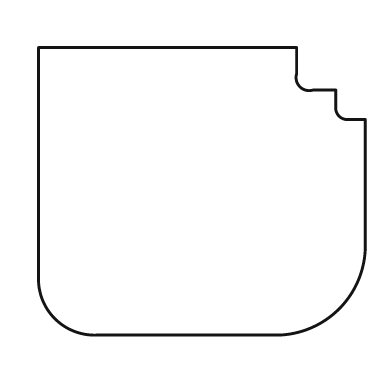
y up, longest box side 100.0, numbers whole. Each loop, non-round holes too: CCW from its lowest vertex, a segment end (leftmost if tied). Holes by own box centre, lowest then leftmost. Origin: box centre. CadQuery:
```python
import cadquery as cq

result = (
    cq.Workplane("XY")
    .moveTo(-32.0, -44.0)
    .lineTo(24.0, -44.0)
    .threePointArc((42.0, -36.0), (50.0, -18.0))
    .lineTo(50.0, 22.0)
    .lineTo(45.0, 22.0)
    .threePointArc((42.0, 23.0), (41.0, 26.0))
    .lineTo(41.0, 31.0)
    .lineTo(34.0, 31.0)
    .threePointArc((30.0, 32.0), (29.0, 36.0))
    .lineTo(29.0, 44.0)
    .lineTo(-50.0, 44.0)
    .lineTo(-50.0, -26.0)
    .threePointArc((-45.0, -39.0), (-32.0, -44.0))
    .close()
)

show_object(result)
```